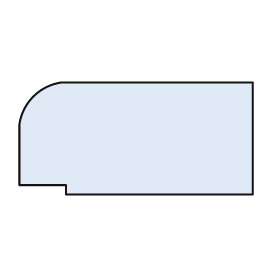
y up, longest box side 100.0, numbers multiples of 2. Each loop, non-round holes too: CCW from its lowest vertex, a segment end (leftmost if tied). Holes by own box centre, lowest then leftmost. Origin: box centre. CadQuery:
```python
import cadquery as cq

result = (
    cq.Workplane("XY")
    .moveTo(-30.0, -24.0)
    .lineTo(50.0, -24.0)
    .lineTo(50.0, 24.0)
    .lineTo(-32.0, 24.0)
    .threePointArc((-44.0, 18.0), (-50.0, 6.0))
    .lineTo(-50.0, -20.0)
    .lineTo(-30.0, -20.0)
    .close()
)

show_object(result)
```